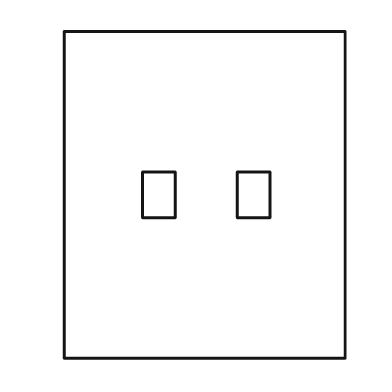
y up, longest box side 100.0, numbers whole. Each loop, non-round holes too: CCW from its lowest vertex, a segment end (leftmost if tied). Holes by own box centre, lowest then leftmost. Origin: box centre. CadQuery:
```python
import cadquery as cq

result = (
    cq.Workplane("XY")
    .moveTo(-43.0, -50.0)
    .lineTo(43.0, -50.0)
    .lineTo(43.0, 50.0)
    .lineTo(-43.0, 50.0)
    .close()
    .moveTo(-19.0, -7.0)
    .lineTo(-9.0, -7.0)
    .lineTo(-9.0, 7.0)
    .lineTo(-19.0, 7.0)
    .close()
    .moveTo(10.0, -7.0)
    .lineTo(20.0, -7.0)
    .lineTo(20.0, 7.0)
    .lineTo(10.0, 7.0)
    .close()
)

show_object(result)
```